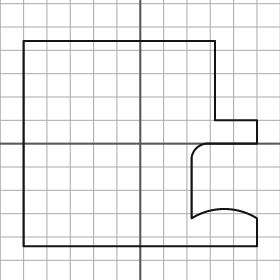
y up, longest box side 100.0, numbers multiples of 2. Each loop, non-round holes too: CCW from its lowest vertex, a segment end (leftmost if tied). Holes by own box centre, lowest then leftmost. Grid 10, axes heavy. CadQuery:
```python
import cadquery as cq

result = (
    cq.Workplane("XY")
    .moveTo(-50.0, -44.0)
    .lineTo(50.0, -44.0)
    .lineTo(50.0, -32.0)
    .threePointArc((36.0, -28.0), (22.0, -32.0))
    .lineTo(22.0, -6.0)
    .threePointArc((24.0, -2.0), (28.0, 0.0))
    .lineTo(50.0, 0.0)
    .lineTo(50.0, 10.0)
    .lineTo(32.0, 10.0)
    .lineTo(32.0, 44.0)
    .lineTo(-50.0, 44.0)
    .close()
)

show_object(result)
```